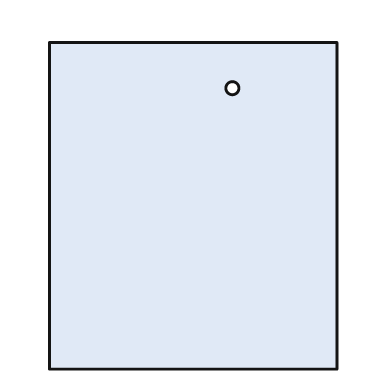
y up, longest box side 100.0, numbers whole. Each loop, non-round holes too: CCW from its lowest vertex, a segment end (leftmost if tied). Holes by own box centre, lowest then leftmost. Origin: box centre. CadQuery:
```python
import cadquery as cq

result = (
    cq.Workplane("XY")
    .moveTo(-44.0, -50.0)
    .lineTo(44.0, -50.0)
    .lineTo(44.0, 50.0)
    .lineTo(-44.0, 50.0)
    .close()
    .moveTo(12.0, 36.0)
    .circle(2.0)
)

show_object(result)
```